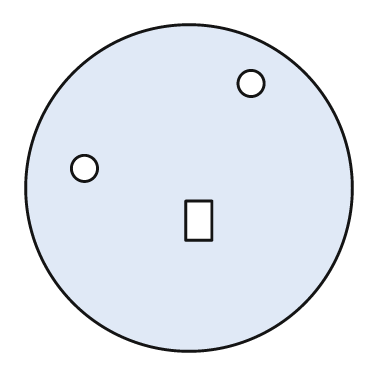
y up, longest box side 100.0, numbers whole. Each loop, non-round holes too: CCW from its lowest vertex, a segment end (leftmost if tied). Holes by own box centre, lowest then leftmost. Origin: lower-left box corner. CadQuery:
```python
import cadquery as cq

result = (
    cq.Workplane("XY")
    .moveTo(50.0, 50.0)
    .circle(50.0)
    .moveTo(49.0, 34.0)
    .lineTo(57.0, 34.0)
    .lineTo(57.0, 46.0)
    .lineTo(49.0, 46.0)
    .close()
    .moveTo(18.0, 56.0)
    .circle(4.0)
    .moveTo(69.0, 82.0)
    .circle(4.0)
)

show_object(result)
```